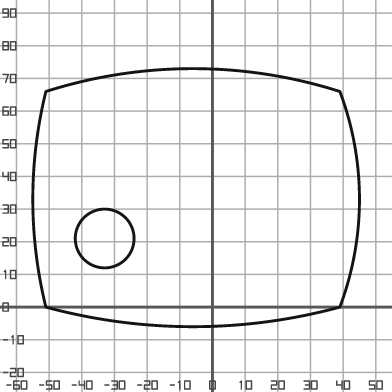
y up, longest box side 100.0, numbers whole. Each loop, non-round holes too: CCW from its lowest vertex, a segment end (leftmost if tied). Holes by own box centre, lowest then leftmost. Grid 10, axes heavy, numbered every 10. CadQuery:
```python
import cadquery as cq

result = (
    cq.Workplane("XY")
    .moveTo(-51.0, 0.0)
    .threePointArc((-6.0, -6.0), (39.0, 0.0))
    .threePointArc((45.0, 33.0), (39.0, 66.0))
    .threePointArc((-6.0, 73.0), (-51.0, 66.0))
    .threePointArc((-55.0, 33.0), (-51.0, 0.0))
    .close()
    .moveTo(-33.0, 21.0)
    .circle(9.0)
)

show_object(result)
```